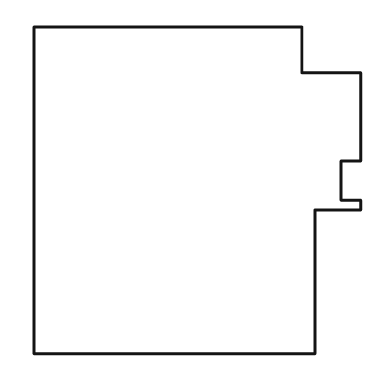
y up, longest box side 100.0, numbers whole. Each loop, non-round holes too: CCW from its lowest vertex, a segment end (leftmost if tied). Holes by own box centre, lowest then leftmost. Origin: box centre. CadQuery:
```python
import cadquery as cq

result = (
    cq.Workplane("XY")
    .moveTo(-50.0, -50.0)
    .lineTo(36.0, -50.0)
    .lineTo(36.0, -6.0)
    .lineTo(50.0, -6.0)
    .lineTo(50.0, -3.0)
    .lineTo(44.0, -3.0)
    .lineTo(44.0, 9.0)
    .lineTo(50.0, 9.0)
    .lineTo(50.0, 36.0)
    .lineTo(32.0, 36.0)
    .lineTo(32.0, 50.0)
    .lineTo(-50.0, 50.0)
    .close()
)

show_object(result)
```